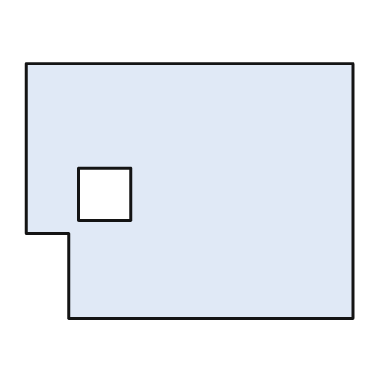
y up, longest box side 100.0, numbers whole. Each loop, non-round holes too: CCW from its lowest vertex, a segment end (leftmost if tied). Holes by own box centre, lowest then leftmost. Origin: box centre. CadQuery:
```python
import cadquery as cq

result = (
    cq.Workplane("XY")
    .moveTo(-37.0, -39.0)
    .lineTo(50.0, -39.0)
    .lineTo(50.0, 39.0)
    .lineTo(-50.0, 39.0)
    .lineTo(-50.0, -13.0)
    .lineTo(-37.0, -13.0)
    .close()
    .moveTo(-34.0, -9.0)
    .lineTo(-18.0, -9.0)
    .lineTo(-18.0, 7.0)
    .lineTo(-34.0, 7.0)
    .close()
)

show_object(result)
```